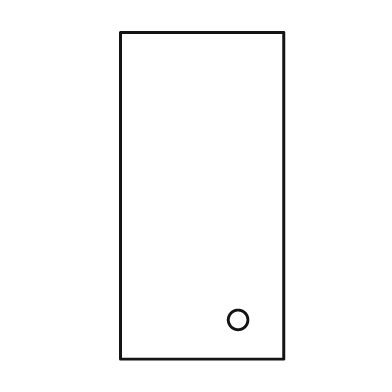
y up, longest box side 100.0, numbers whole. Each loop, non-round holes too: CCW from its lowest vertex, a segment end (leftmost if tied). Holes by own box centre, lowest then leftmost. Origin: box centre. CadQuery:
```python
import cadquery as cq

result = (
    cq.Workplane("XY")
    .moveTo(-25.0, -50.0)
    .lineTo(25.0, -50.0)
    .lineTo(25.0, 50.0)
    .lineTo(-25.0, 50.0)
    .close()
    .moveTo(11.0, -38.0)
    .circle(3.0)
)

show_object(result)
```